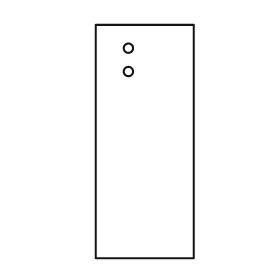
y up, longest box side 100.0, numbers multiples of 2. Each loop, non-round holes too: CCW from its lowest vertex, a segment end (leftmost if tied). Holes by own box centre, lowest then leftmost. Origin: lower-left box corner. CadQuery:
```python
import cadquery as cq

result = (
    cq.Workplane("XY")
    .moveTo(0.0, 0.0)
    .lineTo(42.0, 0.0)
    .lineTo(42.0, 100.0)
    .lineTo(0.0, 100.0)
    .close()
    .moveTo(14.0, 80.0)
    .circle(2.0)
    .moveTo(14.0, 90.0)
    .circle(2.0)
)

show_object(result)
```